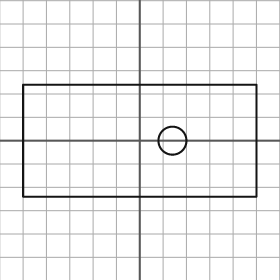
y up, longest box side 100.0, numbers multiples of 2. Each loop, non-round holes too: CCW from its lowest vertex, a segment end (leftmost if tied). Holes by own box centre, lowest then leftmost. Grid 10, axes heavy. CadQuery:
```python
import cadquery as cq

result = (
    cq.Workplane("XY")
    .moveTo(-50.0, -24.0)
    .lineTo(50.0, -24.0)
    .lineTo(50.0, 24.0)
    .lineTo(-50.0, 24.0)
    .close()
    .moveTo(14.0, 0.0)
    .circle(6.0)
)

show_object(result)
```